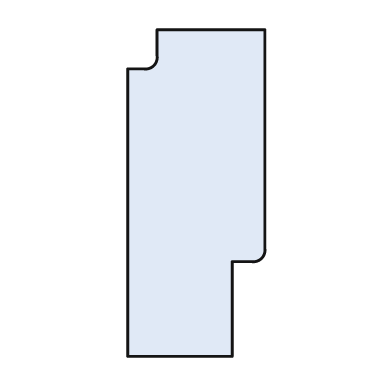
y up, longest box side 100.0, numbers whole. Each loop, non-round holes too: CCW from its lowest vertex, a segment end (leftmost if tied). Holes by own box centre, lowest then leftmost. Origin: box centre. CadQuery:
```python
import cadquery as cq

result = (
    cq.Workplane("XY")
    .moveTo(-21.0, -50.0)
    .lineTo(11.0, -50.0)
    .lineTo(11.0, -21.0)
    .lineTo(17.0, -21.0)
    .threePointArc((20.0, -20.0), (21.0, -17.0))
    .lineTo(21.0, 50.0)
    .lineTo(-12.0, 50.0)
    .lineTo(-12.0, 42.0)
    .threePointArc((-13.0, 39.0), (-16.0, 38.0))
    .lineTo(-21.0, 38.0)
    .close()
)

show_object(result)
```